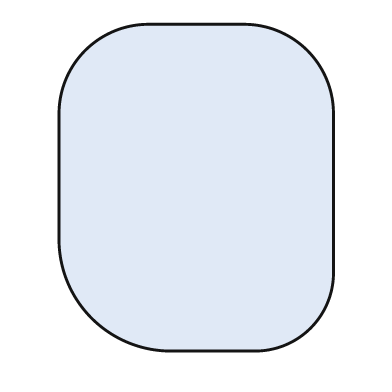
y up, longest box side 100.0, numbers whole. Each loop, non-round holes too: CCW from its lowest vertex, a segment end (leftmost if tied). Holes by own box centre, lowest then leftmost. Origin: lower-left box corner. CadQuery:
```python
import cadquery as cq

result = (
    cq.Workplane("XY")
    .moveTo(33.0, 0.0)
    .lineTo(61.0, 0.0)
    .threePointArc((77.0, 7.0), (84.0, 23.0))
    .lineTo(84.0, 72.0)
    .threePointArc((76.0, 92.0), (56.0, 100.0))
    .lineTo(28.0, 100.0)
    .threePointArc((8.0, 92.0), (0.0, 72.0))
    .lineTo(0.0, 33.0)
    .threePointArc((10.0, 10.0), (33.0, 0.0))
    .close()
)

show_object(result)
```